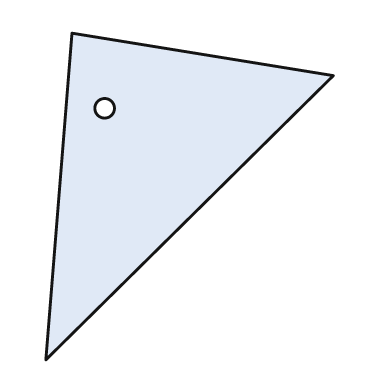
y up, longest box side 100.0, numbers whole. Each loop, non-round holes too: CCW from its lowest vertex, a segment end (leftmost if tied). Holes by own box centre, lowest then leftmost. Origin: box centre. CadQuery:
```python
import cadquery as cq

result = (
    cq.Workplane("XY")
    .moveTo(-44.0, -50.0)
    .lineTo(44.0, 37.0)
    .lineTo(-36.0, 50.0)
    .close()
    .moveTo(-26.0, 27.0)
    .circle(3.0)
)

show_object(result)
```